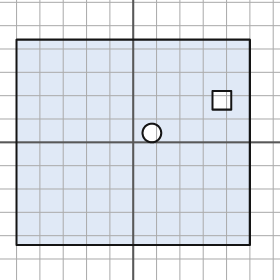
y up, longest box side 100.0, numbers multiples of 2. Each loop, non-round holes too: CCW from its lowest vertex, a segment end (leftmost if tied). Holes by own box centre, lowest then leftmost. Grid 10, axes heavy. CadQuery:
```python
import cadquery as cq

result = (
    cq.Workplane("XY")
    .moveTo(-50.0, -44.0)
    .lineTo(50.0, -44.0)
    .lineTo(50.0, 44.0)
    .lineTo(-50.0, 44.0)
    .close()
    .moveTo(8.0, 4.0)
    .circle(4.0)
    .moveTo(34.0, 14.0)
    .lineTo(42.0, 14.0)
    .lineTo(42.0, 22.0)
    .lineTo(34.0, 22.0)
    .close()
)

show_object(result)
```